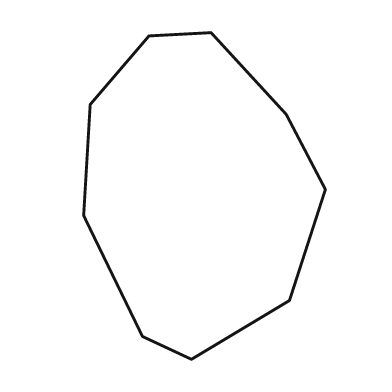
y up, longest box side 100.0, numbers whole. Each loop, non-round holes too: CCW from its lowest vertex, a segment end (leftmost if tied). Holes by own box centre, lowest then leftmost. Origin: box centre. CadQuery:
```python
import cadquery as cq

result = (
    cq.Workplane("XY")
    .moveTo(-4.0, -50.0)
    .lineTo(26.0, -32.0)
    .lineTo(37.0, 2.0)
    .lineTo(25.0, 25.0)
    .lineTo(2.0, 50.0)
    .lineTo(-17.0, 49.0)
    .lineTo(-35.0, 28.0)
    .lineTo(-37.0, -6.0)
    .lineTo(-19.0, -43.0)
    .close()
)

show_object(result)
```